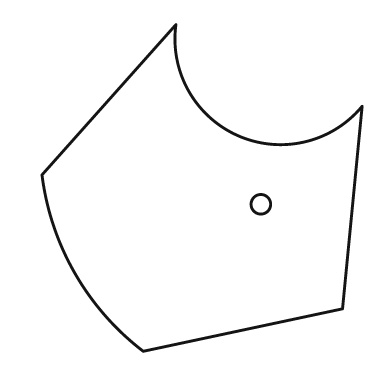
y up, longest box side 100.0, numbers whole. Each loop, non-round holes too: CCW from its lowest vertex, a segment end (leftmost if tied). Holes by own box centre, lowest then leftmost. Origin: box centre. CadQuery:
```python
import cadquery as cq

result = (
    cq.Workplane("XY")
    .moveTo(-18.0, -50.0)
    .lineTo(43.0, -37.0)
    .lineTo(49.0, 25.0)
    .threePointArc((11.0, 16.0), (-8.0, 50.0))
    .lineTo(-49.0, 4.0)
    .threePointArc((-39.0, -26.0), (-18.0, -50.0))
    .close()
    .moveTo(18.0, -5.0)
    .circle(3.0)
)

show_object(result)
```